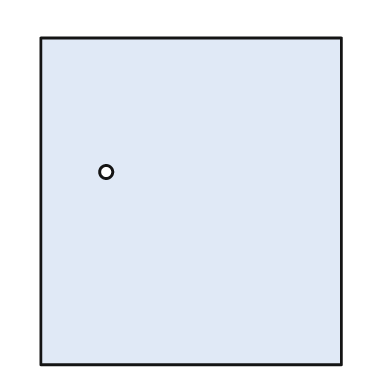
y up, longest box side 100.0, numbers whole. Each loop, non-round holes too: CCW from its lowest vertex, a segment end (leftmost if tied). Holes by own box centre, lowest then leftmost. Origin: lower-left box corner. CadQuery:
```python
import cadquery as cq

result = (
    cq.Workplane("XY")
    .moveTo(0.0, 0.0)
    .lineTo(92.0, 0.0)
    .lineTo(92.0, 100.0)
    .lineTo(0.0, 100.0)
    .close()
    .moveTo(20.0, 59.0)
    .circle(2.0)
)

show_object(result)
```